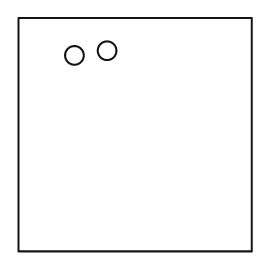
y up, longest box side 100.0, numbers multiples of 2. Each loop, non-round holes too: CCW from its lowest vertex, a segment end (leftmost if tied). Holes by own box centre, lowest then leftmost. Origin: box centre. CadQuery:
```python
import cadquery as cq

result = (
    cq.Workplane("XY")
    .moveTo(-50.0, -50.0)
    .lineTo(50.0, -50.0)
    .lineTo(50.0, 50.0)
    .lineTo(-50.0, 50.0)
    .close()
    .moveTo(-26.0, 34.0)
    .circle(4.0)
    .moveTo(-12.0, 36.0)
    .circle(4.0)
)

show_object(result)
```